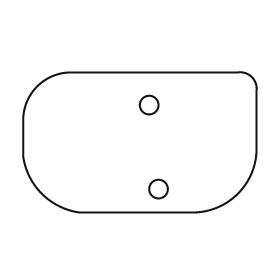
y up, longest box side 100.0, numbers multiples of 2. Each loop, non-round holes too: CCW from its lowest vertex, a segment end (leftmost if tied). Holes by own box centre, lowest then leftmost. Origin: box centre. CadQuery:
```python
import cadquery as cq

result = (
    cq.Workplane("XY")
    .moveTo(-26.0, -30.0)
    .lineTo(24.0, -30.0)
    .threePointArc((42.0, -22.0), (50.0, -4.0))
    .lineTo(50.0, 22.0)
    .threePointArc((48.0, 28.0), (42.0, 30.0))
    .lineTo(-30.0, 30.0)
    .threePointArc((-44.0, 24.0), (-50.0, 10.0))
    .lineTo(-50.0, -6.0)
    .threePointArc((-42.0, -22.0), (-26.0, -30.0))
    .close()
    .moveTo(8.0, -20.0)
    .circle(4.0)
    .moveTo(4.0, 16.0)
    .circle(4.0)
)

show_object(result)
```